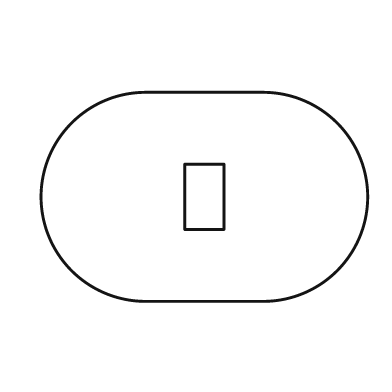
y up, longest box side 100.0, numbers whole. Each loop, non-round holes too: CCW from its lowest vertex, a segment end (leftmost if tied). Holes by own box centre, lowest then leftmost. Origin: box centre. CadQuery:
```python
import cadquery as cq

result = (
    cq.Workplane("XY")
    .moveTo(-18.0, -32.0)
    .lineTo(18.0, -32.0)
    .threePointArc((50.0, 0.0), (18.0, 32.0))
    .lineTo(-18.0, 32.0)
    .threePointArc((-50.0, 0.0), (-18.0, -32.0))
    .close()
    .moveTo(-6.0, -10.0)
    .lineTo(6.0, -10.0)
    .lineTo(6.0, 10.0)
    .lineTo(-6.0, 10.0)
    .close()
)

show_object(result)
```